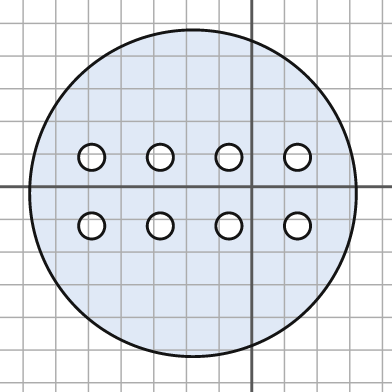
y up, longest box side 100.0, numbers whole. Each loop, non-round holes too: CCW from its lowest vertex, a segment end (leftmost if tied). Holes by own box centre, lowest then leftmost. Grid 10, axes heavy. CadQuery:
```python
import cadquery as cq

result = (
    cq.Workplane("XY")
    .moveTo(-18.0, -2.0)
    .circle(50.0)
    .moveTo(-49.0, -12.0)
    .circle(4.0)
    .moveTo(-28.0, -12.0)
    .circle(4.0)
    .moveTo(-7.0, -12.0)
    .circle(4.0)
    .moveTo(14.0, -12.0)
    .circle(4.0)
    .moveTo(-49.0, 9.0)
    .circle(4.0)
    .moveTo(-28.0, 9.0)
    .circle(4.0)
    .moveTo(-7.0, 9.0)
    .circle(4.0)
    .moveTo(14.0, 9.0)
    .circle(4.0)
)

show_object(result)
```